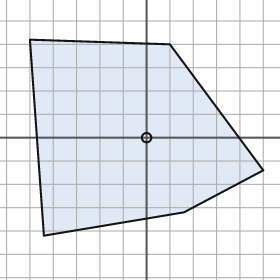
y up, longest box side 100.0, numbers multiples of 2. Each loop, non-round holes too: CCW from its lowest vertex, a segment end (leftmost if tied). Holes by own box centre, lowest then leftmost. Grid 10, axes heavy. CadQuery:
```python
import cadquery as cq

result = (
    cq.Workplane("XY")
    .moveTo(-44.0, -42.0)
    .lineTo(16.0, -32.0)
    .lineTo(50.0, -14.0)
    .lineTo(10.0, 40.0)
    .lineTo(-50.0, 42.0)
    .close()
    .moveTo(0.0, 0.0)
    .circle(2.0)
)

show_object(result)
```